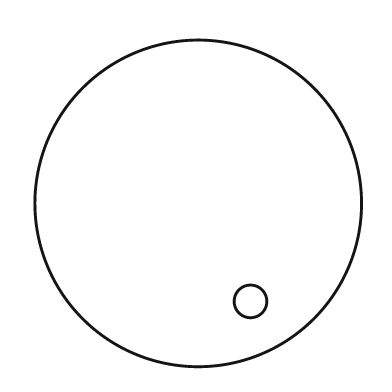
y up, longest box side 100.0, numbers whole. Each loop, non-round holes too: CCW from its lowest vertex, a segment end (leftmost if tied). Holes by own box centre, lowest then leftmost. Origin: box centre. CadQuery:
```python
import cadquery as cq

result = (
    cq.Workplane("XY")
    .moveTo(0.0, 0.0)
    .circle(50.0)
    .moveTo(16.0, -30.0)
    .circle(5.0)
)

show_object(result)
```